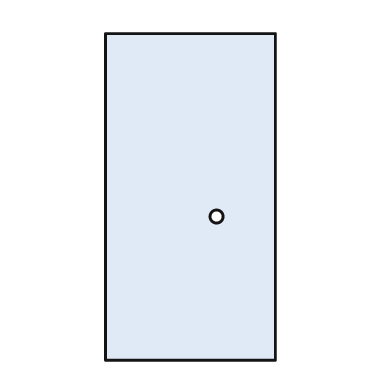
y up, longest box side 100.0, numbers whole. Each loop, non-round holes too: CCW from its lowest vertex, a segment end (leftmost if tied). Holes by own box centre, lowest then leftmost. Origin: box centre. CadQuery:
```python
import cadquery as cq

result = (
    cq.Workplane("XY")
    .moveTo(-26.0, -50.0)
    .lineTo(26.0, -50.0)
    .lineTo(26.0, 50.0)
    .lineTo(-26.0, 50.0)
    .close()
    .moveTo(8.0, -6.0)
    .circle(2.0)
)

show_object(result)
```